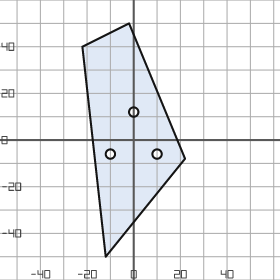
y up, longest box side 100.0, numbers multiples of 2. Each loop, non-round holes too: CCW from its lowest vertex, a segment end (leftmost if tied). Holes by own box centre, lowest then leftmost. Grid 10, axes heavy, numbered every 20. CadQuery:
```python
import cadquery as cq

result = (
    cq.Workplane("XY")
    .moveTo(-12.0, -50.0)
    .lineTo(22.0, -8.0)
    .lineTo(-2.0, 50.0)
    .lineTo(-22.0, 40.0)
    .close()
    .moveTo(-10.0, -6.0)
    .circle(2.0)
    .moveTo(10.0, -6.0)
    .circle(2.0)
    .moveTo(0.0, 12.0)
    .circle(2.0)
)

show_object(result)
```